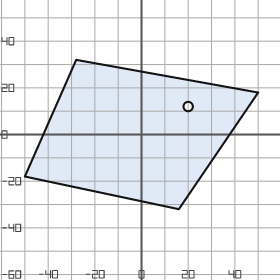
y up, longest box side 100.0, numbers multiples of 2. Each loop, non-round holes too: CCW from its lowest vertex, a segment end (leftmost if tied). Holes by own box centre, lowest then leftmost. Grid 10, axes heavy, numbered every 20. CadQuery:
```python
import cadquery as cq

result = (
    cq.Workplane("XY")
    .moveTo(16.0, -32.0)
    .lineTo(50.0, 18.0)
    .lineTo(-28.0, 32.0)
    .lineTo(-50.0, -18.0)
    .close()
    .moveTo(20.0, 12.0)
    .circle(2.0)
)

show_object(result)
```